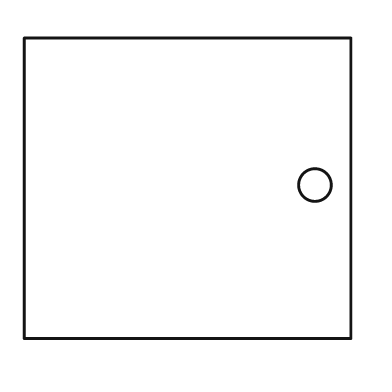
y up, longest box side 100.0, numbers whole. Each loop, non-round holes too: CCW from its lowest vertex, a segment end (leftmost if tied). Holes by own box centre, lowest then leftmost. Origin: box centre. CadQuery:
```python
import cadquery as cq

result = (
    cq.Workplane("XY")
    .moveTo(-50.0, -46.0)
    .lineTo(50.0, -46.0)
    .lineTo(50.0, 46.0)
    .lineTo(-50.0, 46.0)
    .close()
    .moveTo(39.0, 1.0)
    .circle(5.0)
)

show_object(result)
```